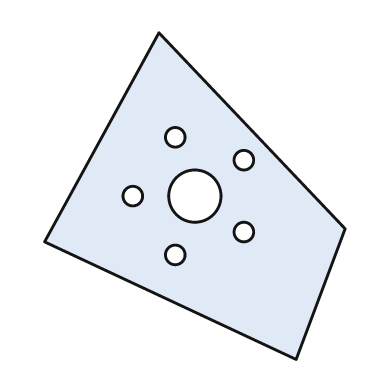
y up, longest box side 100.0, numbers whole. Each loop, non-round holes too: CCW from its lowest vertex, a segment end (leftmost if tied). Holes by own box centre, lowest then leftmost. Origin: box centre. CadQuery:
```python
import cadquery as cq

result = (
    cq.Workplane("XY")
    .moveTo(31.0, -50.0)
    .lineTo(46.0, -10.0)
    .lineTo(-11.0, 50.0)
    .lineTo(-46.0, -14.0)
    .close()
    .moveTo(-6.0, -18.0)
    .circle(3.0)
    .moveTo(15.0, -11.0)
    .circle(3.0)
    .moveTo(-19.0, 0.0)
    .circle(3.0)
    .moveTo(0.0, 0.0)
    .circle(8.0)
    .moveTo(15.0, 11.0)
    .circle(3.0)
    .moveTo(-6.0, 18.0)
    .circle(3.0)
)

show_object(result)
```